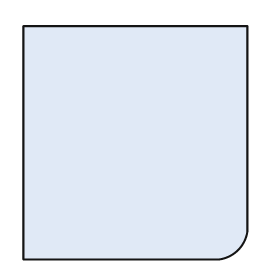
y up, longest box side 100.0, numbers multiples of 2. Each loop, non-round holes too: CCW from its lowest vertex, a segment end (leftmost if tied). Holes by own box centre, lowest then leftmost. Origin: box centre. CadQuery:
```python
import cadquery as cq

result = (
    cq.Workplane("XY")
    .moveTo(-48.0, -50.0)
    .lineTo(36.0, -50.0)
    .threePointArc((44.0, -46.0), (48.0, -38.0))
    .lineTo(48.0, 50.0)
    .lineTo(-48.0, 50.0)
    .close()
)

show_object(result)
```